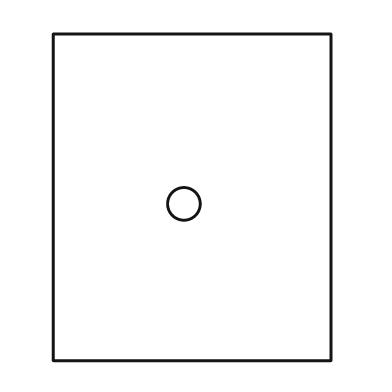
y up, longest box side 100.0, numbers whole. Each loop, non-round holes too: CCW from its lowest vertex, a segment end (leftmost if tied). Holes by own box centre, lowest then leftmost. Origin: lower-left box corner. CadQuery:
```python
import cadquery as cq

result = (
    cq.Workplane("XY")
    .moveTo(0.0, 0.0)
    .lineTo(85.0, 0.0)
    .lineTo(85.0, 100.0)
    .lineTo(0.0, 100.0)
    .close()
    .moveTo(40.0, 48.0)
    .circle(5.0)
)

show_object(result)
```